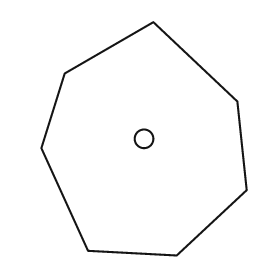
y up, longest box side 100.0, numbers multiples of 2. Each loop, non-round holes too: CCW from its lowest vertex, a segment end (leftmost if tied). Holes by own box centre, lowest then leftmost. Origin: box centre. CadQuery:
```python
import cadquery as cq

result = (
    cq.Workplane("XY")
    .moveTo(14.0, -50.0)
    .lineTo(44.0, -22.0)
    .lineTo(40.0, 16.0)
    .lineTo(4.0, 50.0)
    .lineTo(-34.0, 28.0)
    .lineTo(-44.0, -4.0)
    .lineTo(-24.0, -48.0)
    .close()
    .moveTo(0.0, 0.0)
    .circle(4.0)
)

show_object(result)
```